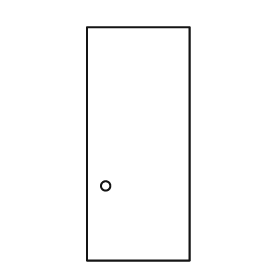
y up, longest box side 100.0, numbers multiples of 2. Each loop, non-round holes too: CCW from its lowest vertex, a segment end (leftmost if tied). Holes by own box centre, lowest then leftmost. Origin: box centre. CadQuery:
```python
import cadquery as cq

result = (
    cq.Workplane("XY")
    .moveTo(-22.0, -50.0)
    .lineTo(22.0, -50.0)
    .lineTo(22.0, 50.0)
    .lineTo(-22.0, 50.0)
    .close()
    .moveTo(-14.0, -18.0)
    .circle(2.0)
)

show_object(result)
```